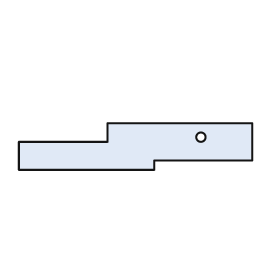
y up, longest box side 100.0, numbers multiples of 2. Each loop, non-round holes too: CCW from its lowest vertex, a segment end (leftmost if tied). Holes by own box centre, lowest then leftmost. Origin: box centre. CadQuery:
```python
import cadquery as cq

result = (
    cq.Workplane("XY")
    .moveTo(-50.0, -10.0)
    .lineTo(8.0, -10.0)
    .lineTo(8.0, -6.0)
    .lineTo(50.0, -6.0)
    .lineTo(50.0, 10.0)
    .lineTo(-12.0, 10.0)
    .lineTo(-12.0, 2.0)
    .lineTo(-50.0, 2.0)
    .close()
    .moveTo(28.0, 4.0)
    .circle(2.0)
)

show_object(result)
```